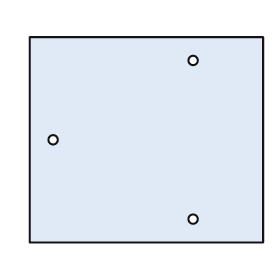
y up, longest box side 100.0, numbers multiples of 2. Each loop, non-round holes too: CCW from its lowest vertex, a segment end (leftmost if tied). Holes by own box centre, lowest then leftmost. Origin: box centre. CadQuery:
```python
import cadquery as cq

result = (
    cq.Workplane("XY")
    .moveTo(-50.0, -44.0)
    .lineTo(50.0, -44.0)
    .lineTo(50.0, 44.0)
    .lineTo(-50.0, 44.0)
    .close()
    .moveTo(20.0, -34.0)
    .circle(2.0)
    .moveTo(-40.0, 0.0)
    .circle(2.0)
    .moveTo(20.0, 34.0)
    .circle(2.0)
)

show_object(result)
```